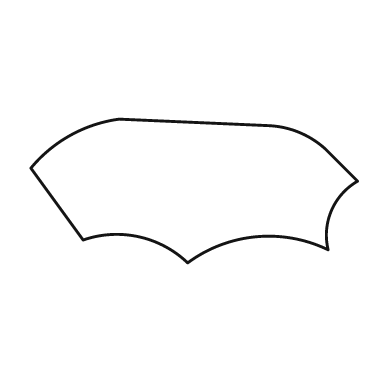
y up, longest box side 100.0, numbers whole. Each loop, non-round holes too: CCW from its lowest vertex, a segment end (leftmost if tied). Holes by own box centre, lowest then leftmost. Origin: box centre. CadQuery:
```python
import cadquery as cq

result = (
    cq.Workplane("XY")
    .moveTo(-2.0, -22.0)
    .threePointArc((19.0, -14.0), (41.0, -18.0))
    .threePointArc((42.0, -6.0), (50.0, 3.0))
    .lineTo(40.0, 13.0)
    .threePointArc((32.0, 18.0), (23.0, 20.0))
    .lineTo(-23.0, 22.0)
    .threePointArc((-38.0, 17.0), (-50.0, 7.0))
    .lineTo(-34.0, -15.0)
    .threePointArc((-17.0, -14.0), (-2.0, -22.0))
    .close()
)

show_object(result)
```